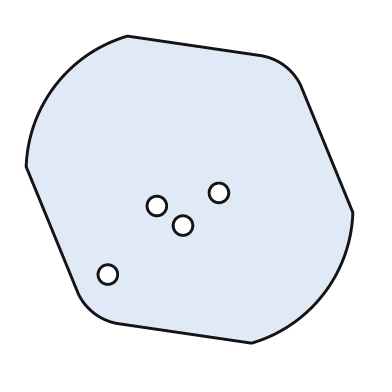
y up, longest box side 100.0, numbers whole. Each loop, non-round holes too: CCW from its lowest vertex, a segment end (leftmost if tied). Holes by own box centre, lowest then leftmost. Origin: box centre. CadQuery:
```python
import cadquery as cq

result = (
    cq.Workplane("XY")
    .moveTo(19.0, -47.0)
    .threePointArc((41.0, -32.0), (50.0, -7.0))
    .lineTo(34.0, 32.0)
    .threePointArc((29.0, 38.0), (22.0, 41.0))
    .lineTo(-19.0, 47.0)
    .threePointArc((-41.0, 32.0), (-50.0, 7.0))
    .lineTo(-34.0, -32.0)
    .threePointArc((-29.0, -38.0), (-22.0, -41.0))
    .close()
    .moveTo(-25.0, -26.0)
    .circle(3.0)
    .moveTo(-2.0, -11.0)
    .circle(3.0)
    .moveTo(-10.0, -5.0)
    .circle(3.0)
    .moveTo(9.0, -1.0)
    .circle(3.0)
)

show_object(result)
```